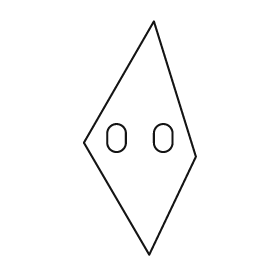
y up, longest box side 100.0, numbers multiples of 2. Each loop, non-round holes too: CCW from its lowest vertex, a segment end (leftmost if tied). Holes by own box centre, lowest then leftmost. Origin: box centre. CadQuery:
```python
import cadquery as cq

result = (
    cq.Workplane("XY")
    .moveTo(4.0, -50.0)
    .lineTo(24.0, -8.0)
    .lineTo(6.0, 50.0)
    .lineTo(-24.0, -2.0)
    .close()
    .moveTo(-14.0, -2.0)
    .threePointArc((-10.0, -6.0), (-6.0, -2.0))
    .lineTo(-6.0, 2.0)
    .threePointArc((-10.0, 6.0), (-14.0, 2.0))
    .close()
    .moveTo(6.0, -2.0)
    .threePointArc((10.0, -6.0), (14.0, -2.0))
    .lineTo(14.0, 2.0)
    .threePointArc((10.0, 6.0), (6.0, 2.0))
    .close()
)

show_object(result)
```